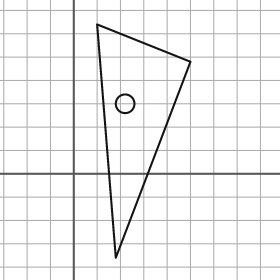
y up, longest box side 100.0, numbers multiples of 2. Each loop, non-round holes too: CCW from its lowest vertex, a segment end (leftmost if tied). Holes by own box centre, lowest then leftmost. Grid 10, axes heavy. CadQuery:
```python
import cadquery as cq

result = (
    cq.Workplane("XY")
    .moveTo(18.0, -36.0)
    .lineTo(50.0, 48.0)
    .lineTo(10.0, 64.0)
    .close()
    .moveTo(22.0, 30.0)
    .circle(4.0)
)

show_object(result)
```